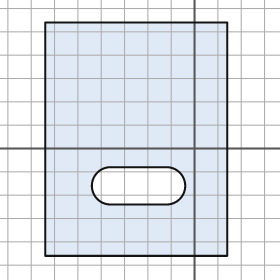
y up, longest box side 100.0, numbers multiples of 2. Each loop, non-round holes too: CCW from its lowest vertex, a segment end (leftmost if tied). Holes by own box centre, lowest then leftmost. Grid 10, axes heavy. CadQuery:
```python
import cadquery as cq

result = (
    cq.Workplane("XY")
    .moveTo(-64.0, -46.0)
    .lineTo(14.0, -46.0)
    .lineTo(14.0, 54.0)
    .lineTo(-64.0, 54.0)
    .close()
    .moveTo(-36.0, -24.0)
    .lineTo(-12.0, -24.0)
    .threePointArc((-4.0, -16.0), (-12.0, -8.0))
    .lineTo(-36.0, -8.0)
    .threePointArc((-44.0, -16.0), (-36.0, -24.0))
    .close()
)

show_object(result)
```